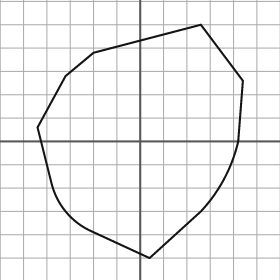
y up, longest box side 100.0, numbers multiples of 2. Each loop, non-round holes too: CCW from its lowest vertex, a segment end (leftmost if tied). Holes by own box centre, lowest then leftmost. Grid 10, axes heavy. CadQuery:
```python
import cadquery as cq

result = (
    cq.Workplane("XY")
    .moveTo(4.0, -50.0)
    .lineTo(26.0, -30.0)
    .threePointArc((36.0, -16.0), (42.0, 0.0))
    .lineTo(44.0, 26.0)
    .lineTo(26.0, 50.0)
    .lineTo(-20.0, 38.0)
    .lineTo(-32.0, 28.0)
    .lineTo(-44.0, 6.0)
    .lineTo(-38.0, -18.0)
    .threePointArc((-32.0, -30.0), (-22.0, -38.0))
    .close()
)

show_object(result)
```